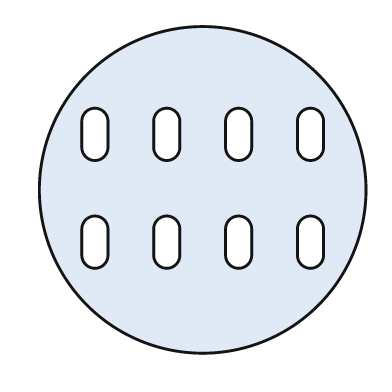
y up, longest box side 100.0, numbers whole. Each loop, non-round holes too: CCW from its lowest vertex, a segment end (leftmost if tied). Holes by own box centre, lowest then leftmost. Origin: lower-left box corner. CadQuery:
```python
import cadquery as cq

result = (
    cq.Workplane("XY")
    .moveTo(50.0, 50.0)
    .circle(50.0)
    .moveTo(13.0, 30.0)
    .threePointArc((17.0, 26.0), (21.0, 30.0))
    .lineTo(21.0, 38.0)
    .threePointArc((17.0, 42.0), (13.0, 38.0))
    .close()
    .moveTo(35.0, 30.0)
    .threePointArc((39.0, 26.0), (43.0, 30.0))
    .lineTo(43.0, 38.0)
    .threePointArc((39.0, 42.0), (35.0, 38.0))
    .close()
    .moveTo(57.0, 30.0)
    .threePointArc((61.0, 26.0), (65.0, 30.0))
    .lineTo(65.0, 38.0)
    .threePointArc((61.0, 42.0), (57.0, 38.0))
    .close()
    .moveTo(79.0, 30.0)
    .threePointArc((83.0, 26.0), (87.0, 30.0))
    .lineTo(87.0, 38.0)
    .threePointArc((83.0, 42.0), (79.0, 38.0))
    .close()
    .moveTo(13.0, 63.0)
    .threePointArc((17.0, 59.0), (21.0, 63.0))
    .lineTo(21.0, 71.0)
    .threePointArc((17.0, 75.0), (13.0, 71.0))
    .close()
    .moveTo(35.0, 63.0)
    .threePointArc((39.0, 59.0), (43.0, 63.0))
    .lineTo(43.0, 71.0)
    .threePointArc((39.0, 75.0), (35.0, 71.0))
    .close()
    .moveTo(57.0, 63.0)
    .threePointArc((61.0, 59.0), (65.0, 63.0))
    .lineTo(65.0, 71.0)
    .threePointArc((61.0, 75.0), (57.0, 71.0))
    .close()
    .moveTo(79.0, 63.0)
    .threePointArc((83.0, 59.0), (87.0, 63.0))
    .lineTo(87.0, 71.0)
    .threePointArc((83.0, 75.0), (79.0, 71.0))
    .close()
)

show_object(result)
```